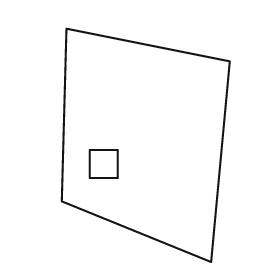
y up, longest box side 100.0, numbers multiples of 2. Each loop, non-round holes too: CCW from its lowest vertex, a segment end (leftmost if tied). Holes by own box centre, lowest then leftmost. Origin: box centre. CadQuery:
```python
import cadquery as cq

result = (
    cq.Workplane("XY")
    .moveTo(28.0, -50.0)
    .lineTo(36.0, 36.0)
    .lineTo(-34.0, 50.0)
    .lineTo(-36.0, -24.0)
    .close()
    .moveTo(-24.0, -14.0)
    .lineTo(-12.0, -14.0)
    .lineTo(-12.0, -2.0)
    .lineTo(-24.0, -2.0)
    .close()
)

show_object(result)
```